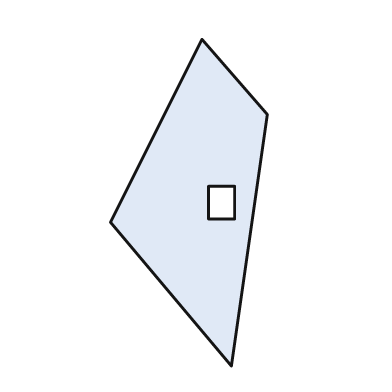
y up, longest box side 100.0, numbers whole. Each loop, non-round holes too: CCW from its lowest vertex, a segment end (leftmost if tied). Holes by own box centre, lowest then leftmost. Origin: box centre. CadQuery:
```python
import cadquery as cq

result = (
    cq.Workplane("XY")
    .moveTo(13.0, -50.0)
    .lineTo(24.0, 27.0)
    .lineTo(4.0, 50.0)
    .lineTo(-24.0, -6.0)
    .close()
    .moveTo(6.0, -5.0)
    .lineTo(14.0, -5.0)
    .lineTo(14.0, 5.0)
    .lineTo(6.0, 5.0)
    .close()
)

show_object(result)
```